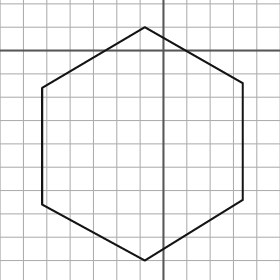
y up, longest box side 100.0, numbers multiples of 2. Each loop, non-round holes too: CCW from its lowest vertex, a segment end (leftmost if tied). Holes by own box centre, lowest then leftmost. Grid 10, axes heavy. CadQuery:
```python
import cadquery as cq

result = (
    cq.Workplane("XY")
    .moveTo(-8.0, -90.0)
    .lineTo(34.0, -64.0)
    .lineTo(34.0, -14.0)
    .lineTo(-8.0, 10.0)
    .lineTo(-52.0, -16.0)
    .lineTo(-52.0, -66.0)
    .close()
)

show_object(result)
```